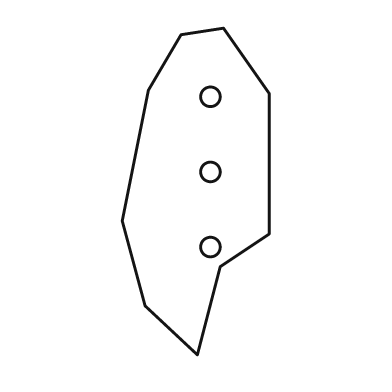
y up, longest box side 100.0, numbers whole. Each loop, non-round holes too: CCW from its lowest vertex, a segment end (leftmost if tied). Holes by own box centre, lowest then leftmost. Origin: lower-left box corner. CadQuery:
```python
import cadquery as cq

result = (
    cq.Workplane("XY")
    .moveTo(23.0, 0.0)
    .lineTo(30.0, 27.0)
    .lineTo(45.0, 37.0)
    .lineTo(45.0, 80.0)
    .lineTo(31.0, 100.0)
    .lineTo(18.0, 98.0)
    .lineTo(8.0, 81.0)
    .lineTo(0.0, 41.0)
    .lineTo(7.0, 15.0)
    .close()
    .moveTo(27.0, 33.0)
    .circle(3.0)
    .moveTo(27.0, 56.0)
    .circle(3.0)
    .moveTo(27.0, 79.0)
    .circle(3.0)
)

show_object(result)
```